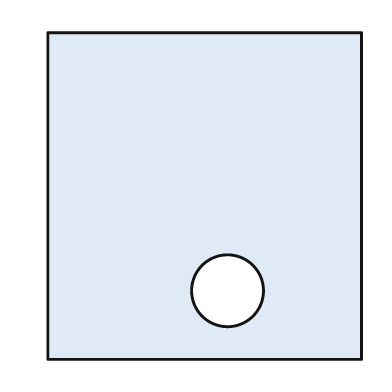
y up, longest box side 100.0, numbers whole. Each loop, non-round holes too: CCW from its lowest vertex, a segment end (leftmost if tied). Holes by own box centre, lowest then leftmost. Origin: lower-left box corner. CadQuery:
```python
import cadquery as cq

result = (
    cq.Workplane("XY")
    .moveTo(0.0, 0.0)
    .lineTo(96.0, 0.0)
    .lineTo(96.0, 100.0)
    .lineTo(0.0, 100.0)
    .close()
    .moveTo(55.0, 21.0)
    .circle(11.0)
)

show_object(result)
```